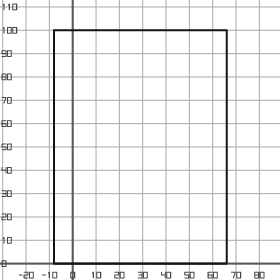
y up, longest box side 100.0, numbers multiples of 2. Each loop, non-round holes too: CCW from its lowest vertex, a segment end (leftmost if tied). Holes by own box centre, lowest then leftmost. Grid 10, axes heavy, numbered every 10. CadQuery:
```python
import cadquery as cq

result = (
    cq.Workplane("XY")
    .moveTo(-8.0, 0.0)
    .lineTo(66.0, 0.0)
    .lineTo(66.0, 100.0)
    .lineTo(-8.0, 100.0)
    .close()
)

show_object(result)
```